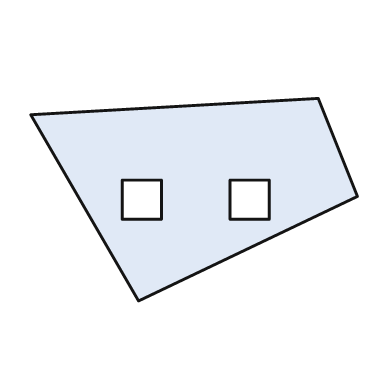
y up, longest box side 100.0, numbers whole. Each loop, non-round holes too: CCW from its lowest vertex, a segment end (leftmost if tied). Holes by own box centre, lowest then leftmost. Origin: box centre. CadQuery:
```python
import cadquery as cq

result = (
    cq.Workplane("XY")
    .moveTo(-17.0, -31.0)
    .lineTo(50.0, 1.0)
    .lineTo(38.0, 31.0)
    .lineTo(-50.0, 26.0)
    .close()
    .moveTo(-22.0, -6.0)
    .lineTo(-10.0, -6.0)
    .lineTo(-10.0, 6.0)
    .lineTo(-22.0, 6.0)
    .close()
    .moveTo(11.0, -6.0)
    .lineTo(23.0, -6.0)
    .lineTo(23.0, 6.0)
    .lineTo(11.0, 6.0)
    .close()
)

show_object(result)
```